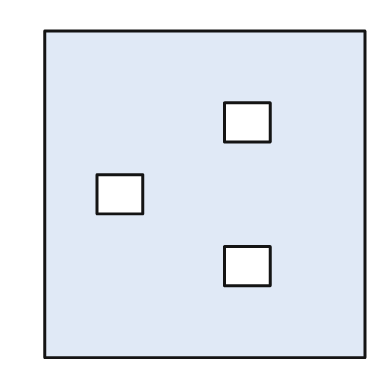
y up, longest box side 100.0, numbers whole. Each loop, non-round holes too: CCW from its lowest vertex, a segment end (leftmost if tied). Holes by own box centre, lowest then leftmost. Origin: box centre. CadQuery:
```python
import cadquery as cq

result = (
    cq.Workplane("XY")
    .moveTo(-49.0, -50.0)
    .lineTo(49.0, -50.0)
    .lineTo(49.0, 50.0)
    .lineTo(-49.0, 50.0)
    .close()
    .moveTo(6.0, -28.0)
    .lineTo(20.0, -28.0)
    .lineTo(20.0, -16.0)
    .lineTo(6.0, -16.0)
    .close()
    .moveTo(-33.0, -6.0)
    .lineTo(-19.0, -6.0)
    .lineTo(-19.0, 6.0)
    .lineTo(-33.0, 6.0)
    .close()
    .moveTo(6.0, 16.0)
    .lineTo(20.0, 16.0)
    .lineTo(20.0, 28.0)
    .lineTo(6.0, 28.0)
    .close()
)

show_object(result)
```